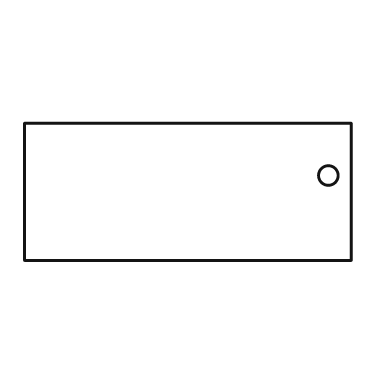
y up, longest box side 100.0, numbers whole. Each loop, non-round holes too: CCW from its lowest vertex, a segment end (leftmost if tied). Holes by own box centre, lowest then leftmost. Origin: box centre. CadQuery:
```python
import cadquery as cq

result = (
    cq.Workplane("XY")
    .moveTo(-50.0, -21.0)
    .lineTo(50.0, -21.0)
    .lineTo(50.0, 21.0)
    .lineTo(-50.0, 21.0)
    .close()
    .moveTo(43.0, 5.0)
    .circle(3.0)
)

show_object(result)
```